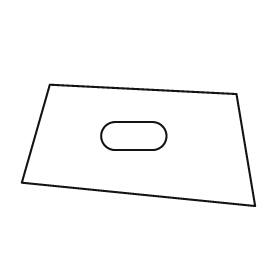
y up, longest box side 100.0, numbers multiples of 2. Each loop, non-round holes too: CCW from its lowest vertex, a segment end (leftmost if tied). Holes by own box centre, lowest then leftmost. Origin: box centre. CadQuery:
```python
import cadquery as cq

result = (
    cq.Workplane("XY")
    .moveTo(50.0, -26.0)
    .lineTo(42.0, 22.0)
    .lineTo(-38.0, 26.0)
    .lineTo(-50.0, -16.0)
    .close()
    .moveTo(-10.0, -2.0)
    .lineTo(6.0, -2.0)
    .threePointArc((12.0, 4.0), (6.0, 10.0))
    .lineTo(-10.0, 10.0)
    .threePointArc((-16.0, 4.0), (-10.0, -2.0))
    .close()
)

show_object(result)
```